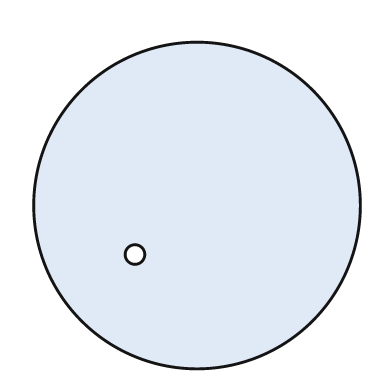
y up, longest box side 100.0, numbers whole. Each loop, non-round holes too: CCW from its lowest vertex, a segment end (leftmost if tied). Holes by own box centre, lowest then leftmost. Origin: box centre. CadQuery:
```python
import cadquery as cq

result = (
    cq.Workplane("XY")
    .moveTo(0.0, 0.0)
    .circle(50.0)
    .moveTo(-19.0, -15.0)
    .circle(3.0)
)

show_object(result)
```